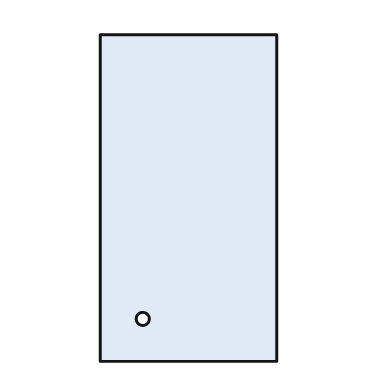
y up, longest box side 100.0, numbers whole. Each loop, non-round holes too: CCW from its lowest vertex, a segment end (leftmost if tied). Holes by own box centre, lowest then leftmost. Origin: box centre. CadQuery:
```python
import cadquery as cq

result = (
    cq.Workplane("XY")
    .moveTo(-27.0, -50.0)
    .lineTo(27.0, -50.0)
    .lineTo(27.0, 50.0)
    .lineTo(-27.0, 50.0)
    .close()
    .moveTo(-14.0, -37.0)
    .circle(2.0)
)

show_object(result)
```